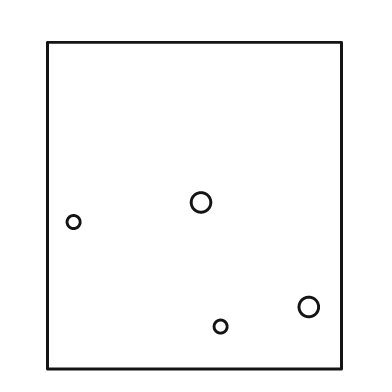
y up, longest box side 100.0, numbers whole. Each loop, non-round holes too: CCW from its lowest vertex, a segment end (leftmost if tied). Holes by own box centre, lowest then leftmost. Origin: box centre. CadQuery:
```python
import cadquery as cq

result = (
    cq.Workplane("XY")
    .moveTo(-45.0, -50.0)
    .lineTo(45.0, -50.0)
    .lineTo(45.0, 50.0)
    .lineTo(-45.0, 50.0)
    .close()
    .moveTo(8.0, -37.0)
    .circle(2.0)
    .moveTo(35.0, -31.0)
    .circle(3.0)
    .moveTo(-37.0, -5.0)
    .circle(2.0)
    .moveTo(2.0, 1.0)
    .circle(3.0)
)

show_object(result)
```